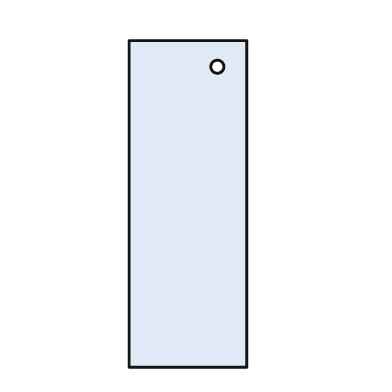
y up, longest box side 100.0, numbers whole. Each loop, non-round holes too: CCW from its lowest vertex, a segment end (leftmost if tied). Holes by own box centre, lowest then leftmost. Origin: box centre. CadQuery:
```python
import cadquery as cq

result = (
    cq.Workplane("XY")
    .moveTo(-18.0, -50.0)
    .lineTo(18.0, -50.0)
    .lineTo(18.0, 50.0)
    .lineTo(-18.0, 50.0)
    .close()
    .moveTo(9.0, 42.0)
    .circle(2.0)
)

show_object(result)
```